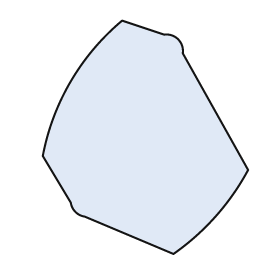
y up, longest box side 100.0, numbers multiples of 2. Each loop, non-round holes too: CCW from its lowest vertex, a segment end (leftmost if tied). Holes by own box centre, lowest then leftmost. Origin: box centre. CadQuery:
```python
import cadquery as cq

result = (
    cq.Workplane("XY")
    .moveTo(12.0, -50.0)
    .threePointArc((30.0, -34.0), (44.0, -14.0))
    .lineTo(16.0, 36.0)
    .threePointArc((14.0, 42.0), (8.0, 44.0))
    .lineTo(-10.0, 50.0)
    .threePointArc((-32.0, 24.0), (-44.0, -8.0))
    .lineTo(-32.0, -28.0)
    .threePointArc((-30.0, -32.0), (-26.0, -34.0))
    .close()
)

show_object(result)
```